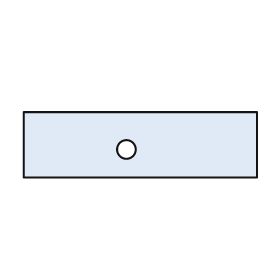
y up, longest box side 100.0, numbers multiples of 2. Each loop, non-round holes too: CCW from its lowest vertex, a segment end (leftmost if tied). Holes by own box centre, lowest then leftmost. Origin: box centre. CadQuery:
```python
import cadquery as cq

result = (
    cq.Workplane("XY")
    .moveTo(-50.0, -14.0)
    .lineTo(50.0, -14.0)
    .lineTo(50.0, 14.0)
    .lineTo(-50.0, 14.0)
    .close()
    .moveTo(-6.0, -2.0)
    .circle(4.0)
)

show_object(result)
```